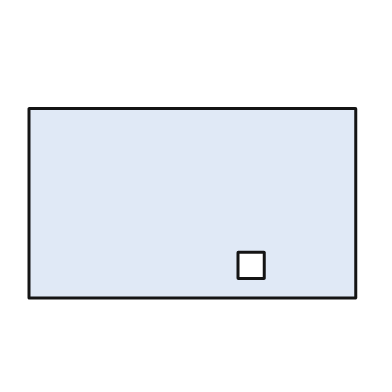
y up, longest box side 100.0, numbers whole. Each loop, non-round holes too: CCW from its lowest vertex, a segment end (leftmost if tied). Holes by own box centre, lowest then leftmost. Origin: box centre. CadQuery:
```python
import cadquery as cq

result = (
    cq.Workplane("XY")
    .moveTo(-50.0, -29.0)
    .lineTo(50.0, -29.0)
    .lineTo(50.0, 29.0)
    .lineTo(-50.0, 29.0)
    .close()
    .moveTo(14.0, -23.0)
    .lineTo(22.0, -23.0)
    .lineTo(22.0, -15.0)
    .lineTo(14.0, -15.0)
    .close()
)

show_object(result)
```